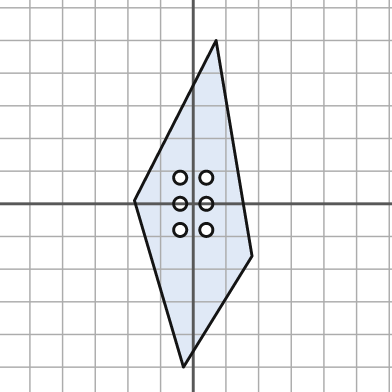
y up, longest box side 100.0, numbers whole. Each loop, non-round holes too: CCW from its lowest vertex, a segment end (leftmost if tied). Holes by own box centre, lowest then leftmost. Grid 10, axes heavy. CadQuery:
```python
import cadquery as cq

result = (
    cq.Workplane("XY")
    .moveTo(-3.0, -50.0)
    .lineTo(18.0, -16.0)
    .lineTo(7.0, 50.0)
    .lineTo(-18.0, 1.0)
    .close()
    .moveTo(-4.0, -8.0)
    .circle(2.0)
    .moveTo(4.0, -8.0)
    .circle(2.0)
    .moveTo(-4.0, 0.0)
    .circle(2.0)
    .moveTo(4.0, 0.0)
    .circle(2.0)
    .moveTo(-4.0, 8.0)
    .circle(2.0)
    .moveTo(4.0, 8.0)
    .circle(2.0)
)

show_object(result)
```